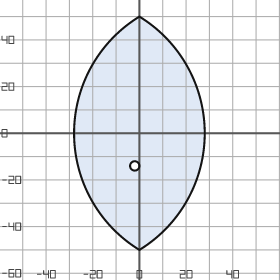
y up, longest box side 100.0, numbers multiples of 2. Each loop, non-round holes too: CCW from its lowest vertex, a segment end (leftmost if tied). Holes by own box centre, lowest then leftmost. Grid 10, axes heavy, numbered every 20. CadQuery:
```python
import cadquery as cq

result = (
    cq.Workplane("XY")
    .moveTo(0.0, -50.0)
    .threePointArc((28.0, 0.0), (0.0, 50.0))
    .threePointArc((-28.0, 0.0), (0.0, -50.0))
    .close()
    .moveTo(-2.0, -14.0)
    .circle(2.0)
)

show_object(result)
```